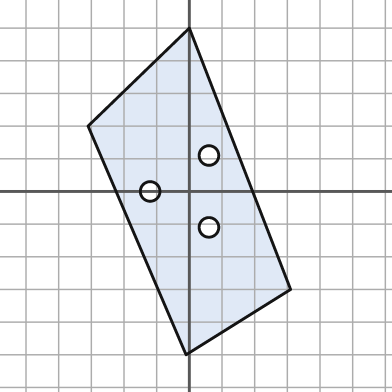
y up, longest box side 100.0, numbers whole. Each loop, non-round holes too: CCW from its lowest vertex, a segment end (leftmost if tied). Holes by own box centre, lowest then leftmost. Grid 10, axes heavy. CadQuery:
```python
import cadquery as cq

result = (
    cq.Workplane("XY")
    .moveTo(-1.0, -50.0)
    .lineTo(31.0, -30.0)
    .lineTo(0.0, 50.0)
    .lineTo(-31.0, 20.0)
    .close()
    .moveTo(6.0, -11.0)
    .circle(3.0)
    .moveTo(-12.0, 0.0)
    .circle(3.0)
    .moveTo(6.0, 11.0)
    .circle(3.0)
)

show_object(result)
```